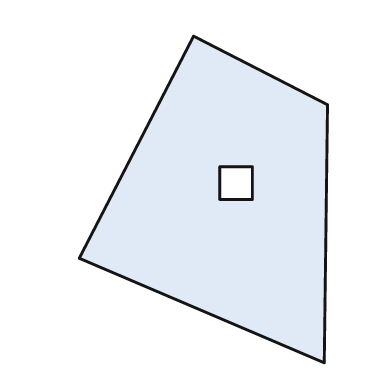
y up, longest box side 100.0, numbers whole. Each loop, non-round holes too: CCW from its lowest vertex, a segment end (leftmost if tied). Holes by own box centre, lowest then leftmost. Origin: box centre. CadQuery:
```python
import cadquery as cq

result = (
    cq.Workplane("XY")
    .moveTo(37.0, -50.0)
    .lineTo(38.0, 29.0)
    .lineTo(-3.0, 50.0)
    .lineTo(-38.0, -18.0)
    .close()
    .moveTo(5.0, 0.0)
    .lineTo(15.0, 0.0)
    .lineTo(15.0, 10.0)
    .lineTo(5.0, 10.0)
    .close()
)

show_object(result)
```